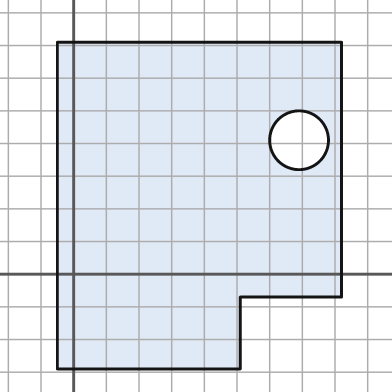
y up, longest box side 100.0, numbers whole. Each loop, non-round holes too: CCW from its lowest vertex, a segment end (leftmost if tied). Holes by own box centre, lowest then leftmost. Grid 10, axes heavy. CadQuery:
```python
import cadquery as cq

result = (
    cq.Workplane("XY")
    .moveTo(-5.0, -29.0)
    .lineTo(51.0, -29.0)
    .lineTo(51.0, -7.0)
    .lineTo(82.0, -7.0)
    .lineTo(82.0, 71.0)
    .lineTo(-5.0, 71.0)
    .close()
    .moveTo(69.0, 41.0)
    .circle(9.0)
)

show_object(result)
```